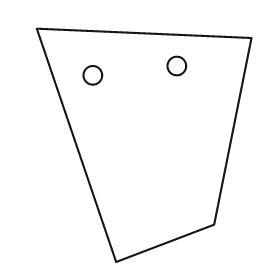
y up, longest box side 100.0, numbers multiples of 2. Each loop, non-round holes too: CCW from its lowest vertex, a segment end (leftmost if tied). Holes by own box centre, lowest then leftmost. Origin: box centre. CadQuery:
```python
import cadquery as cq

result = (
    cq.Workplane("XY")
    .moveTo(-12.0, -50.0)
    .lineTo(30.0, -34.0)
    .lineTo(46.0, 46.0)
    .lineTo(-46.0, 50.0)
    .close()
    .moveTo(-22.0, 30.0)
    .circle(4.0)
    .moveTo(14.0, 34.0)
    .circle(4.0)
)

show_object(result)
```